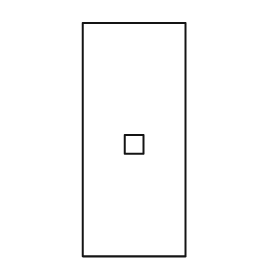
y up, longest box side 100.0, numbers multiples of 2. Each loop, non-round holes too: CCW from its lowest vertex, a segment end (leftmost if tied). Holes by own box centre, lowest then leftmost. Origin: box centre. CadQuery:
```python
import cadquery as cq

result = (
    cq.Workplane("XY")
    .moveTo(-22.0, -50.0)
    .lineTo(22.0, -50.0)
    .lineTo(22.0, 50.0)
    .lineTo(-22.0, 50.0)
    .close()
    .moveTo(-4.0, -6.0)
    .lineTo(4.0, -6.0)
    .lineTo(4.0, 2.0)
    .lineTo(-4.0, 2.0)
    .close()
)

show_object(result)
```